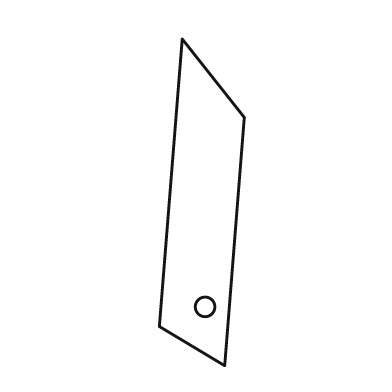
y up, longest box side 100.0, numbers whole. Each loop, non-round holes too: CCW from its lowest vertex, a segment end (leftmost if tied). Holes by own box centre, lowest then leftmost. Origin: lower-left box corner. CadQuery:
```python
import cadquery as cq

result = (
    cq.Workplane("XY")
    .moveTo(20.0, 0.0)
    .lineTo(26.0, 76.0)
    .lineTo(7.0, 100.0)
    .lineTo(0.0, 12.0)
    .close()
    .moveTo(14.0, 18.0)
    .circle(3.0)
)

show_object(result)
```